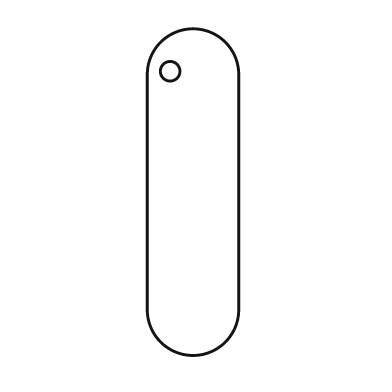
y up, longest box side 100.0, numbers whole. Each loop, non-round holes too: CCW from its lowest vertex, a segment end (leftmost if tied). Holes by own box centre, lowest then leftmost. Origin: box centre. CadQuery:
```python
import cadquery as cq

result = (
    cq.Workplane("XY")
    .moveTo(-14.0, -36.0)
    .threePointArc((0.0, -50.0), (14.0, -36.0))
    .lineTo(14.0, 36.0)
    .threePointArc((0.0, 50.0), (-14.0, 36.0))
    .close()
    .moveTo(-7.0, 37.0)
    .circle(3.0)
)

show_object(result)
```